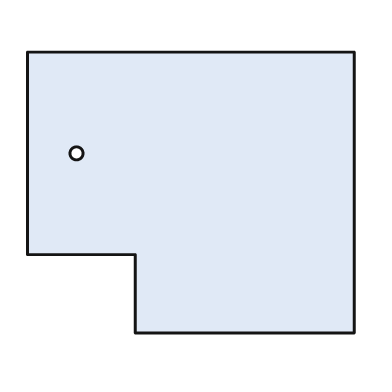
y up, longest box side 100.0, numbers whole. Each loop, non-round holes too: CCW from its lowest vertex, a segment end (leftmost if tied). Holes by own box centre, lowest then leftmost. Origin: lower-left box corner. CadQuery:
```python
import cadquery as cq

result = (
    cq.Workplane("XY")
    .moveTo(33.0, 0.0)
    .lineTo(100.0, 0.0)
    .lineTo(100.0, 86.0)
    .lineTo(0.0, 86.0)
    .lineTo(0.0, 24.0)
    .lineTo(33.0, 24.0)
    .close()
    .moveTo(15.0, 55.0)
    .circle(2.0)
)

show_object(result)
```